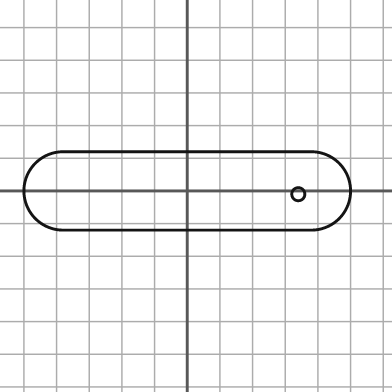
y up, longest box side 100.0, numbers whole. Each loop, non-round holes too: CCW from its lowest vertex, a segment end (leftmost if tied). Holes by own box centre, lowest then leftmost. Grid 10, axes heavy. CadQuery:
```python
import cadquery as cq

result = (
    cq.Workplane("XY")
    .moveTo(-38.0, -12.0)
    .lineTo(38.0, -12.0)
    .threePointArc((50.0, 0.0), (38.0, 12.0))
    .lineTo(-38.0, 12.0)
    .threePointArc((-50.0, 0.0), (-38.0, -12.0))
    .close()
    .moveTo(34.0, -1.0)
    .circle(2.0)
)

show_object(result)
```